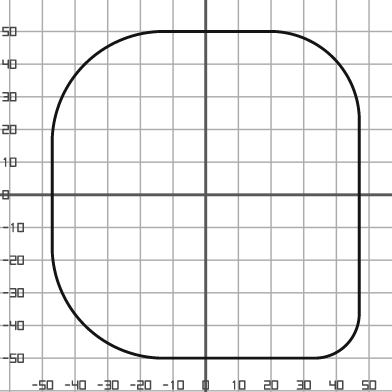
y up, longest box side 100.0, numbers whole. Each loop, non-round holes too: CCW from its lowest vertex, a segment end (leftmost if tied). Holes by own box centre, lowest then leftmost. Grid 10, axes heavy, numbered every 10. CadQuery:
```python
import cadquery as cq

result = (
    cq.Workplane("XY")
    .moveTo(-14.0, -50.0)
    .lineTo(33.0, -50.0)
    .threePointArc((43.0, -46.0), (47.0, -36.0))
    .lineTo(47.0, 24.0)
    .threePointArc((39.0, 42.0), (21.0, 50.0))
    .lineTo(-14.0, 50.0)
    .threePointArc((-37.0, 40.0), (-47.0, 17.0))
    .lineTo(-47.0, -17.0)
    .threePointArc((-37.0, -40.0), (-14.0, -50.0))
    .close()
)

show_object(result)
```